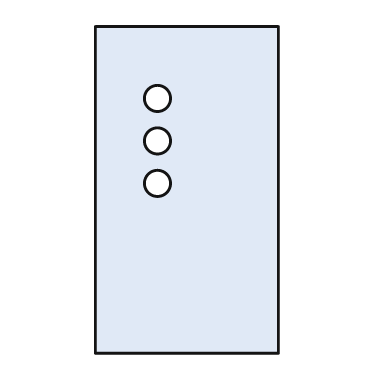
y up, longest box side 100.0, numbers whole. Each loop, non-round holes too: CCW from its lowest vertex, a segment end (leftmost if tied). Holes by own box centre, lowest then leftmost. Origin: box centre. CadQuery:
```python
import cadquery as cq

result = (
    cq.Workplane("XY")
    .moveTo(-28.0, -50.0)
    .lineTo(28.0, -50.0)
    .lineTo(28.0, 50.0)
    .lineTo(-28.0, 50.0)
    .close()
    .moveTo(-9.0, 2.0)
    .circle(4.0)
    .moveTo(-9.0, 15.0)
    .circle(4.0)
    .moveTo(-9.0, 28.0)
    .circle(4.0)
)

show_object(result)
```